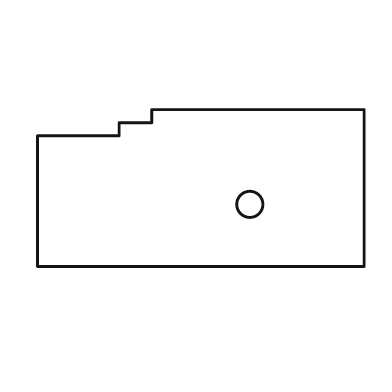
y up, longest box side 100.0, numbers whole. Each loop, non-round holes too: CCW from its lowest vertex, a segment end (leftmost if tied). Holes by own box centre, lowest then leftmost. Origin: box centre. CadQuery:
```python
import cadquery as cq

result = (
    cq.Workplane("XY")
    .moveTo(-50.0, -24.0)
    .lineTo(50.0, -24.0)
    .lineTo(50.0, 24.0)
    .lineTo(-15.0, 24.0)
    .lineTo(-15.0, 20.0)
    .lineTo(-25.0, 20.0)
    .lineTo(-25.0, 16.0)
    .lineTo(-50.0, 16.0)
    .close()
    .moveTo(15.0, -5.0)
    .circle(4.0)
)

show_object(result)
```